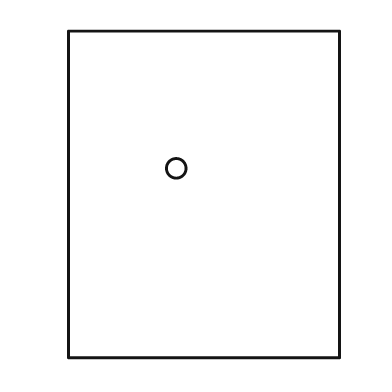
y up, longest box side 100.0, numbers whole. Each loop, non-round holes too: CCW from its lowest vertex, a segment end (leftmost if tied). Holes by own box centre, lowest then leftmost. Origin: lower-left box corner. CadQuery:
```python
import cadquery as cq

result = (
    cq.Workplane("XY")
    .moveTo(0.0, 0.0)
    .lineTo(83.0, 0.0)
    .lineTo(83.0, 100.0)
    .lineTo(0.0, 100.0)
    .close()
    .moveTo(33.0, 58.0)
    .circle(3.0)
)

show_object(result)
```